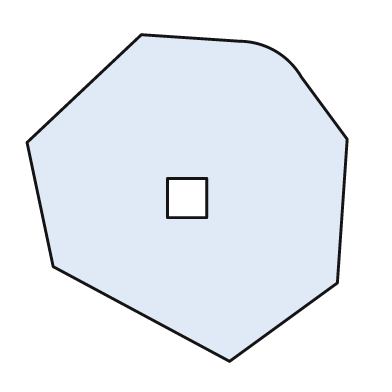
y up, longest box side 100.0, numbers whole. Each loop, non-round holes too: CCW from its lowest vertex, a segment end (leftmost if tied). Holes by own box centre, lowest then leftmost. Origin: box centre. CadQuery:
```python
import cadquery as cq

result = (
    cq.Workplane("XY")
    .moveTo(13.0, -50.0)
    .lineTo(46.0, -26.0)
    .lineTo(49.0, 18.0)
    .lineTo(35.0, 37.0)
    .threePointArc((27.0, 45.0), (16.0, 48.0))
    .lineTo(-14.0, 50.0)
    .lineTo(-49.0, 17.0)
    .lineTo(-41.0, -21.0)
    .close()
    .moveTo(-6.0, -6.0)
    .lineTo(6.0, -6.0)
    .lineTo(6.0, 6.0)
    .lineTo(-6.0, 6.0)
    .close()
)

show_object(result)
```